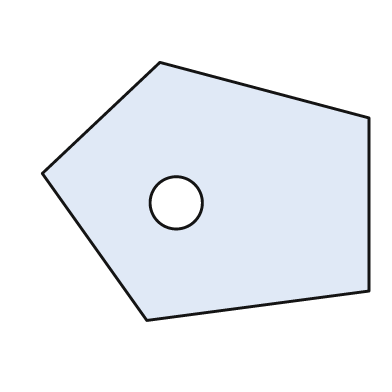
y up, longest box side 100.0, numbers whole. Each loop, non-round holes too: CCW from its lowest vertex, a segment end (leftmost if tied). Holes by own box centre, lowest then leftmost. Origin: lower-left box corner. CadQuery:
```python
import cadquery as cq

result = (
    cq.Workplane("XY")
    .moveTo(32.0, 0.0)
    .lineTo(100.0, 9.0)
    .lineTo(100.0, 62.0)
    .lineTo(36.0, 79.0)
    .lineTo(0.0, 45.0)
    .close()
    .moveTo(41.0, 36.0)
    .circle(8.0)
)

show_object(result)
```